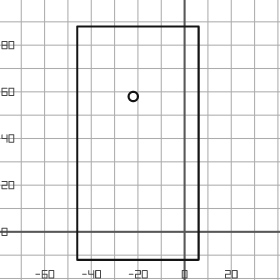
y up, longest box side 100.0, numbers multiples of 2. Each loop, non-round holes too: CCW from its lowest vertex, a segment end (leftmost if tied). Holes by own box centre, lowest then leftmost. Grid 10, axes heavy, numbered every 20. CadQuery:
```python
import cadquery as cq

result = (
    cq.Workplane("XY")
    .moveTo(-46.0, -12.0)
    .lineTo(6.0, -12.0)
    .lineTo(6.0, 88.0)
    .lineTo(-46.0, 88.0)
    .close()
    .moveTo(-22.0, 58.0)
    .circle(2.0)
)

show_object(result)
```